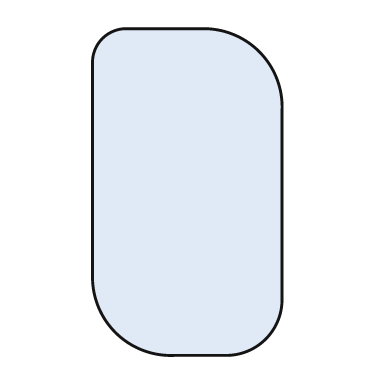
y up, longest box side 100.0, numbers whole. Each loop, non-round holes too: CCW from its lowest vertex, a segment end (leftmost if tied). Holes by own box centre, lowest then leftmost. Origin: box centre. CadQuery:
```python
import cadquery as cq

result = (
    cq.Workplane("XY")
    .moveTo(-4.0, -50.0)
    .lineTo(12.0, -50.0)
    .threePointArc((24.0, -45.0), (29.0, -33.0))
    .lineTo(29.0, 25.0)
    .threePointArc((22.0, 43.0), (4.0, 50.0))
    .lineTo(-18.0, 50.0)
    .threePointArc((-26.0, 47.0), (-29.0, 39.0))
    .lineTo(-29.0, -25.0)
    .threePointArc((-22.0, -43.0), (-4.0, -50.0))
    .close()
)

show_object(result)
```